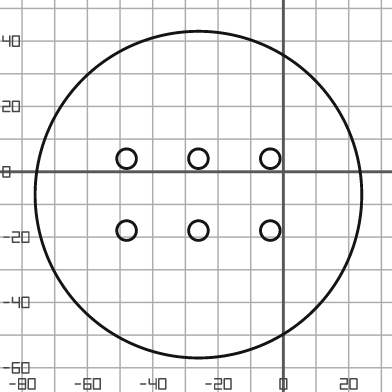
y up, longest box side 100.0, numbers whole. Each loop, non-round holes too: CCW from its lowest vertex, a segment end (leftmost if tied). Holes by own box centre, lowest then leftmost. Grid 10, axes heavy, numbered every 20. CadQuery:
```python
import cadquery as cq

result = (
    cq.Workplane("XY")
    .moveTo(-26.0, -7.0)
    .circle(50.0)
    .moveTo(-48.0, -18.0)
    .circle(3.0)
    .moveTo(-26.0, -18.0)
    .circle(3.0)
    .moveTo(-4.0, -18.0)
    .circle(3.0)
    .moveTo(-48.0, 4.0)
    .circle(3.0)
    .moveTo(-26.0, 4.0)
    .circle(3.0)
    .moveTo(-4.0, 4.0)
    .circle(3.0)
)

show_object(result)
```